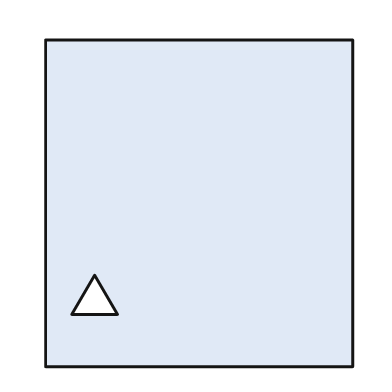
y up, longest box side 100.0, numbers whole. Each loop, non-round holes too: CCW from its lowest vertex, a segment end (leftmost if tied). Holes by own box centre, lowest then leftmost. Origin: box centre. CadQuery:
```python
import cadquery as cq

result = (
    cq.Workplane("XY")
    .moveTo(-47.0, -50.0)
    .lineTo(47.0, -50.0)
    .lineTo(47.0, 50.0)
    .lineTo(-47.0, 50.0)
    .close()
    .moveTo(-39.0, -34.0)
    .lineTo(-25.0, -34.0)
    .lineTo(-32.0, -22.0)
    .close()
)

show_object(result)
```